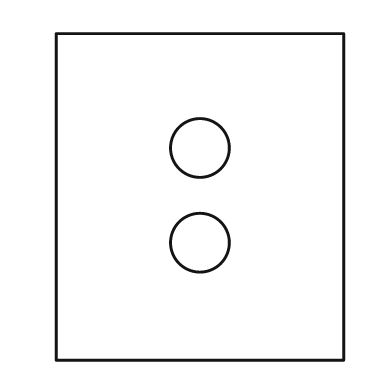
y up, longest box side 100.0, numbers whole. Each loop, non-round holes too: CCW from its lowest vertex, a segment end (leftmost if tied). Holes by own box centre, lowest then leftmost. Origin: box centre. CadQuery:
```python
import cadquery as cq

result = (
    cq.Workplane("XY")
    .moveTo(-44.0, -50.0)
    .lineTo(44.0, -50.0)
    .lineTo(44.0, 50.0)
    .lineTo(-44.0, 50.0)
    .close()
    .moveTo(0.0, -14.0)
    .circle(9.0)
    .moveTo(0.0, 15.0)
    .circle(9.0)
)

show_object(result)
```